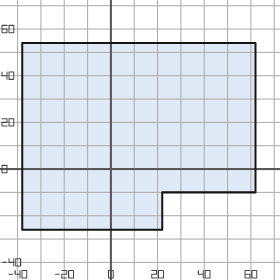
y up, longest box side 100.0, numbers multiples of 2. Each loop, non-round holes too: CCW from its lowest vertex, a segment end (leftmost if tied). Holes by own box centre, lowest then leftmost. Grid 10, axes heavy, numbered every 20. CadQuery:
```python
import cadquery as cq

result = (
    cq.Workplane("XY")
    .moveTo(-38.0, -26.0)
    .lineTo(22.0, -26.0)
    .lineTo(22.0, -10.0)
    .lineTo(62.0, -10.0)
    .lineTo(62.0, 54.0)
    .lineTo(-38.0, 54.0)
    .close()
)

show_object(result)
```